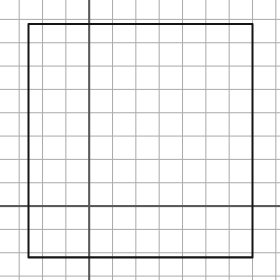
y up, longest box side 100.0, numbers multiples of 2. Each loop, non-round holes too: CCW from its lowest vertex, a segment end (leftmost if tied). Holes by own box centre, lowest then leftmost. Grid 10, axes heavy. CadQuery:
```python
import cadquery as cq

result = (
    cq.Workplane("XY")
    .moveTo(-26.0, -22.0)
    .lineTo(70.0, -22.0)
    .lineTo(70.0, 78.0)
    .lineTo(-26.0, 78.0)
    .close()
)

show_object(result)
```